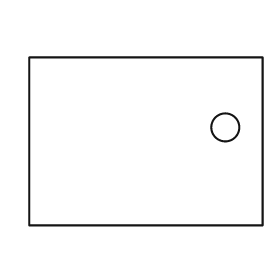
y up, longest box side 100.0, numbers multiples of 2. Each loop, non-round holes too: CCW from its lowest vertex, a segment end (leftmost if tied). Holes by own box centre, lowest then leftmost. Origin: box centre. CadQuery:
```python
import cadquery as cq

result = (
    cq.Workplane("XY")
    .moveTo(-50.0, -36.0)
    .lineTo(50.0, -36.0)
    .lineTo(50.0, 36.0)
    .lineTo(-50.0, 36.0)
    .close()
    .moveTo(34.0, 6.0)
    .circle(6.0)
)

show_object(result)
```